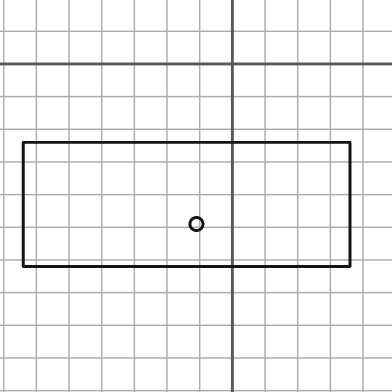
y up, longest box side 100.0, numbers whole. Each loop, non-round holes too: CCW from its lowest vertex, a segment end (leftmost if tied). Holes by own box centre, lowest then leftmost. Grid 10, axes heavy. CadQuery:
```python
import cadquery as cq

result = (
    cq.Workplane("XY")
    .moveTo(-64.0, -62.0)
    .lineTo(36.0, -62.0)
    .lineTo(36.0, -24.0)
    .lineTo(-64.0, -24.0)
    .close()
    .moveTo(-11.0, -49.0)
    .circle(2.0)
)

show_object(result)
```